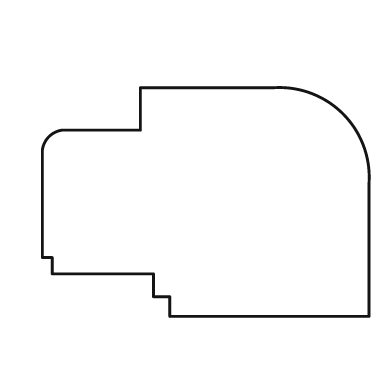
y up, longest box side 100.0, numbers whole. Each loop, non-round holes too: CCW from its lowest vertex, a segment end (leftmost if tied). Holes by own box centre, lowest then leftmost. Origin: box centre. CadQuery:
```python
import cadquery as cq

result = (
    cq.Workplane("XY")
    .moveTo(-11.0, -35.0)
    .lineTo(50.0, -35.0)
    .lineTo(50.0, 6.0)
    .threePointArc((42.0, 27.0), (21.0, 35.0))
    .lineTo(-20.0, 35.0)
    .lineTo(-20.0, 22.0)
    .lineTo(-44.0, 22.0)
    .threePointArc((-48.0, 20.0), (-50.0, 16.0))
    .lineTo(-50.0, -17.0)
    .lineTo(-47.0, -17.0)
    .lineTo(-47.0, -22.0)
    .lineTo(-16.0, -22.0)
    .lineTo(-16.0, -29.0)
    .lineTo(-11.0, -29.0)
    .close()
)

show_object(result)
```